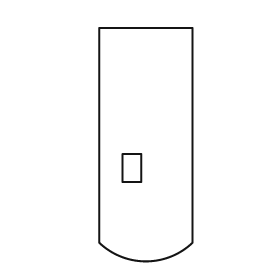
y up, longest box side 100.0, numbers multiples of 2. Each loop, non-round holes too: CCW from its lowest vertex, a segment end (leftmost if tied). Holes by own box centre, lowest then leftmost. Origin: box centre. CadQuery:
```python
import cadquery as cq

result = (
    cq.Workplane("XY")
    .moveTo(-20.0, -42.0)
    .threePointArc((0.0, -50.0), (20.0, -42.0))
    .lineTo(20.0, 50.0)
    .lineTo(-20.0, 50.0)
    .close()
    .moveTo(-10.0, -16.0)
    .lineTo(-2.0, -16.0)
    .lineTo(-2.0, -4.0)
    .lineTo(-10.0, -4.0)
    .close()
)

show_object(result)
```